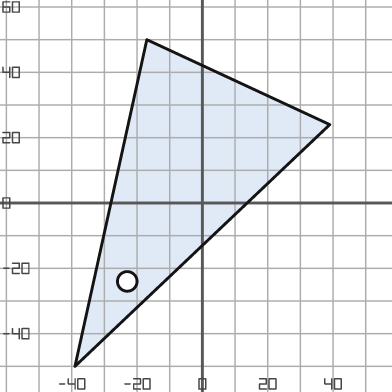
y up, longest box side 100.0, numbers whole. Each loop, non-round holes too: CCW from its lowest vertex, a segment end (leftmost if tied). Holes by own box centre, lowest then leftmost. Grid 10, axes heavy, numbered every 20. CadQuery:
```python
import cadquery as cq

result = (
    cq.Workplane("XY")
    .moveTo(-39.0, -50.0)
    .lineTo(39.0, 24.0)
    .lineTo(-17.0, 50.0)
    .close()
    .moveTo(-23.0, -24.0)
    .circle(3.0)
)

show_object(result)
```